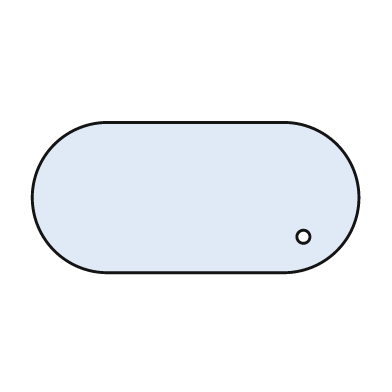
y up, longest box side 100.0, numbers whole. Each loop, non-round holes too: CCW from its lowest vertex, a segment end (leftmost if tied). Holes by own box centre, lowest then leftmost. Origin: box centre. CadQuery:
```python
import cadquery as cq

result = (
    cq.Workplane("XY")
    .moveTo(-27.0, -23.0)
    .lineTo(27.0, -23.0)
    .threePointArc((50.0, 0.0), (27.0, 23.0))
    .lineTo(-27.0, 23.0)
    .threePointArc((-50.0, 0.0), (-27.0, -23.0))
    .close()
    .moveTo(33.0, -12.0)
    .circle(2.0)
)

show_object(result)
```